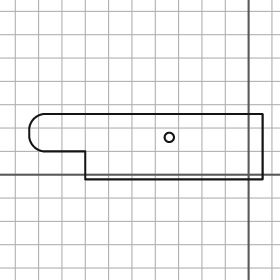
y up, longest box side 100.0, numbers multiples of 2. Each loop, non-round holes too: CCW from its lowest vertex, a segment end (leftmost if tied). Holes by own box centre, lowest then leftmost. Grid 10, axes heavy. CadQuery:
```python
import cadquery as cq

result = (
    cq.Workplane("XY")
    .moveTo(-70.0, -2.0)
    .lineTo(6.0, -2.0)
    .lineTo(6.0, 26.0)
    .lineTo(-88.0, 26.0)
    .threePointArc((-92.0, 24.0), (-94.0, 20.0))
    .lineTo(-94.0, 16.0)
    .threePointArc((-92.0, 12.0), (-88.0, 10.0))
    .lineTo(-70.0, 10.0)
    .close()
    .moveTo(-34.0, 16.0)
    .circle(2.0)
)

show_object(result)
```